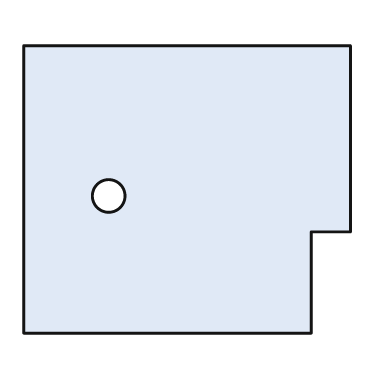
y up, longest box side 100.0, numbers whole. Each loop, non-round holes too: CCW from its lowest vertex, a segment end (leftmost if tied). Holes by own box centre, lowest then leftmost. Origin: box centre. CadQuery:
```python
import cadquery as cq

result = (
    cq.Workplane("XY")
    .moveTo(-50.0, -44.0)
    .lineTo(38.0, -44.0)
    .lineTo(38.0, -13.0)
    .lineTo(50.0, -13.0)
    .lineTo(50.0, 44.0)
    .lineTo(-50.0, 44.0)
    .close()
    .moveTo(-24.0, -2.0)
    .circle(5.0)
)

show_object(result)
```